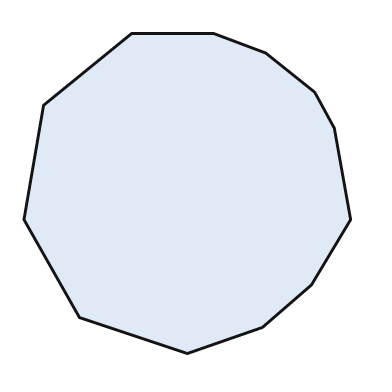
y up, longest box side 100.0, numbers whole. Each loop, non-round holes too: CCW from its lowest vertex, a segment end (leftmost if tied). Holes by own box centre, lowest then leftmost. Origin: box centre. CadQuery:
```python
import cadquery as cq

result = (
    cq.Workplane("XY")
    .moveTo(0.0, -49.0)
    .lineTo(23.0, -41.0)
    .lineTo(38.0, -28.0)
    .lineTo(50.0, -8.0)
    .lineTo(45.0, 20.0)
    .lineTo(39.0, 31.0)
    .lineTo(24.0, 43.0)
    .lineTo(8.0, 49.0)
    .lineTo(-17.0, 49.0)
    .lineTo(-44.0, 27.0)
    .lineTo(-50.0, -8.0)
    .lineTo(-33.0, -38.0)
    .close()
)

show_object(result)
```